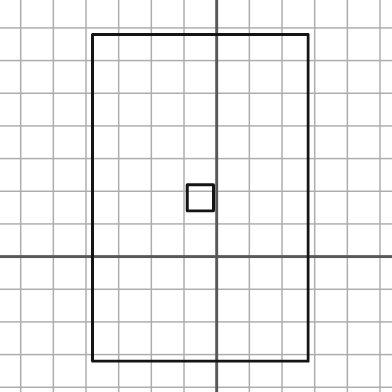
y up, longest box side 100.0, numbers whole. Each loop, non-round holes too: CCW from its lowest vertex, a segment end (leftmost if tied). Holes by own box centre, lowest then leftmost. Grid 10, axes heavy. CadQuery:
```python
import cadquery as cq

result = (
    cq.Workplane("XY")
    .moveTo(-38.0, -32.0)
    .lineTo(28.0, -32.0)
    .lineTo(28.0, 68.0)
    .lineTo(-38.0, 68.0)
    .close()
    .moveTo(-9.0, 14.0)
    .lineTo(-1.0, 14.0)
    .lineTo(-1.0, 22.0)
    .lineTo(-9.0, 22.0)
    .close()
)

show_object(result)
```